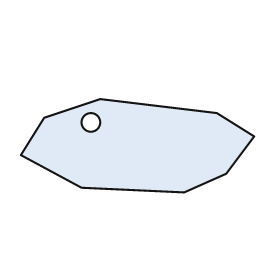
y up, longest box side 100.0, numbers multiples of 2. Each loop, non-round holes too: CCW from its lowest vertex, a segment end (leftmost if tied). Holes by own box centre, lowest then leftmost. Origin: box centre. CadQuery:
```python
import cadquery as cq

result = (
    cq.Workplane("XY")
    .moveTo(20.0, -20.0)
    .lineTo(38.0, -12.0)
    .lineTo(50.0, 4.0)
    .lineTo(34.0, 14.0)
    .lineTo(-16.0, 20.0)
    .lineTo(-40.0, 12.0)
    .lineTo(-50.0, -4.0)
    .lineTo(-24.0, -18.0)
    .close()
    .moveTo(-20.0, 10.0)
    .circle(4.0)
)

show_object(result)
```